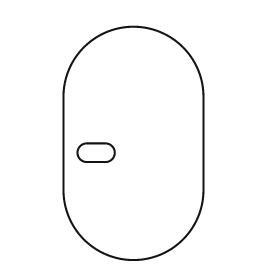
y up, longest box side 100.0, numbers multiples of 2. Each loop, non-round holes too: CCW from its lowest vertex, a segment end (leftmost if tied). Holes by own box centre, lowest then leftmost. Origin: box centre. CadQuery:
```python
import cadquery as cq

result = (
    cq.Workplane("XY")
    .moveTo(-30.0, -20.0)
    .threePointArc((0.0, -50.0), (30.0, -20.0))
    .lineTo(30.0, 20.0)
    .threePointArc((0.0, 50.0), (-30.0, 20.0))
    .close()
    .moveTo(-20.0, -8.0)
    .lineTo(-12.0, -8.0)
    .threePointArc((-8.0, -4.0), (-12.0, 0.0))
    .lineTo(-20.0, 0.0)
    .threePointArc((-24.0, -4.0), (-20.0, -8.0))
    .close()
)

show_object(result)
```